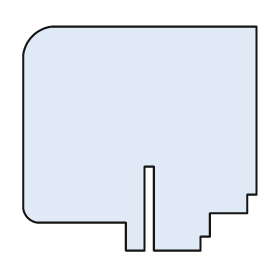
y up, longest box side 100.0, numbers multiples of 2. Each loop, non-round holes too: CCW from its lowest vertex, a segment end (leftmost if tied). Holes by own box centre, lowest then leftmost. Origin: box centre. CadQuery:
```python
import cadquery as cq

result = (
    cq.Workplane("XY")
    .moveTo(-6.0, -48.0)
    .lineTo(2.0, -48.0)
    .lineTo(2.0, -12.0)
    .lineTo(6.0, -12.0)
    .lineTo(6.0, -48.0)
    .lineTo(26.0, -48.0)
    .lineTo(26.0, -42.0)
    .lineTo(30.0, -42.0)
    .lineTo(30.0, -32.0)
    .lineTo(46.0, -32.0)
    .lineTo(46.0, -24.0)
    .lineTo(50.0, -24.0)
    .lineTo(50.0, 48.0)
    .lineTo(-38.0, 48.0)
    .threePointArc((-46.0, 44.0), (-50.0, 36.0))
    .lineTo(-50.0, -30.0)
    .threePointArc((-48.0, -34.0), (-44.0, -36.0))
    .lineTo(-6.0, -36.0)
    .close()
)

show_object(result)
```